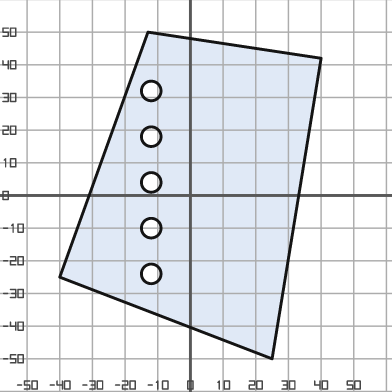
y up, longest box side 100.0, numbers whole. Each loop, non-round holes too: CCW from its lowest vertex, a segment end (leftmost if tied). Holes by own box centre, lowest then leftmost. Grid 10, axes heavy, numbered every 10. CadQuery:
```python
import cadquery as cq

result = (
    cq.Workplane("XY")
    .moveTo(25.0, -50.0)
    .lineTo(40.0, 42.0)
    .lineTo(-13.0, 50.0)
    .lineTo(-40.0, -25.0)
    .close()
    .moveTo(-12.0, -24.0)
    .circle(3.0)
    .moveTo(-12.0, -10.0)
    .circle(3.0)
    .moveTo(-12.0, 4.0)
    .circle(3.0)
    .moveTo(-12.0, 18.0)
    .circle(3.0)
    .moveTo(-12.0, 32.0)
    .circle(3.0)
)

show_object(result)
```